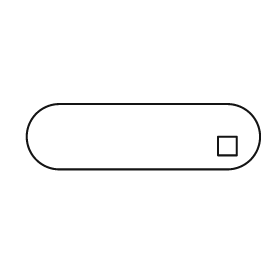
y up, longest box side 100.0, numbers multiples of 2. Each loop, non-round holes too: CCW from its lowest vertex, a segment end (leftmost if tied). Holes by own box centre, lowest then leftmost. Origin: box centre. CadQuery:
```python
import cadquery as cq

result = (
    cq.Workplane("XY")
    .moveTo(-36.0, -14.0)
    .lineTo(36.0, -14.0)
    .threePointArc((50.0, 0.0), (36.0, 14.0))
    .lineTo(-36.0, 14.0)
    .threePointArc((-50.0, 0.0), (-36.0, -14.0))
    .close()
    .moveTo(32.0, -8.0)
    .lineTo(40.0, -8.0)
    .lineTo(40.0, 0.0)
    .lineTo(32.0, 0.0)
    .close()
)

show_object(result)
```